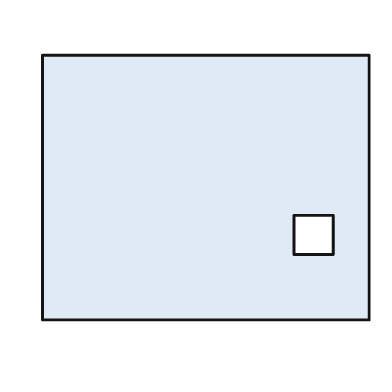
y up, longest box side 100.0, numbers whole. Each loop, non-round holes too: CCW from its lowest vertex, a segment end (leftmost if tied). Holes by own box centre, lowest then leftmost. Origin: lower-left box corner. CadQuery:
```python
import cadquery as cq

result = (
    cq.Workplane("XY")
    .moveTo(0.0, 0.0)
    .lineTo(100.0, 0.0)
    .lineTo(100.0, 81.0)
    .lineTo(0.0, 81.0)
    .close()
    .moveTo(77.0, 20.0)
    .lineTo(89.0, 20.0)
    .lineTo(89.0, 32.0)
    .lineTo(77.0, 32.0)
    .close()
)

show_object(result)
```